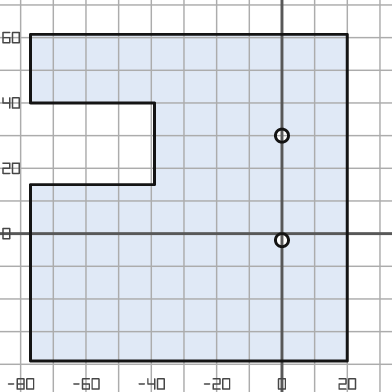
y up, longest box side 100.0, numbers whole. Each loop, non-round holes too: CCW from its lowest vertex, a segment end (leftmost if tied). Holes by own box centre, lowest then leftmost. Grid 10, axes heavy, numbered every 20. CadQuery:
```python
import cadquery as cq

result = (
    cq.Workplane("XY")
    .moveTo(-77.0, -39.0)
    .lineTo(20.0, -39.0)
    .lineTo(20.0, 61.0)
    .lineTo(-77.0, 61.0)
    .lineTo(-77.0, 40.0)
    .lineTo(-39.0, 40.0)
    .lineTo(-39.0, 15.0)
    .lineTo(-77.0, 15.0)
    .close()
    .moveTo(0.0, -2.0)
    .circle(2.0)
    .moveTo(0.0, 30.0)
    .circle(2.0)
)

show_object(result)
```